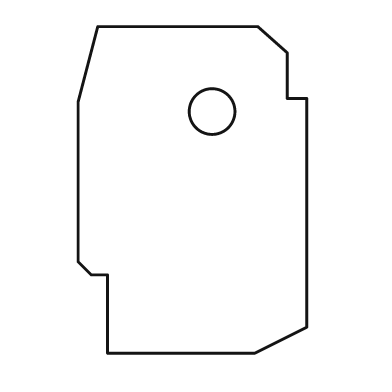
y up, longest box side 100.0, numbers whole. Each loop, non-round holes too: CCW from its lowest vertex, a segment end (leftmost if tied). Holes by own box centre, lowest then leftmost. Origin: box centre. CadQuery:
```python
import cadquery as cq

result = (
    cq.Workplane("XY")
    .moveTo(-26.0, -50.0)
    .lineTo(19.0, -50.0)
    .lineTo(35.0, -42.0)
    .lineTo(35.0, 28.0)
    .lineTo(29.0, 28.0)
    .lineTo(29.0, 42.0)
    .lineTo(20.0, 50.0)
    .lineTo(-29.0, 50.0)
    .lineTo(-35.0, 27.0)
    .lineTo(-35.0, -22.0)
    .lineTo(-31.0, -26.0)
    .lineTo(-26.0, -26.0)
    .close()
    .moveTo(6.0, 24.0)
    .circle(7.0)
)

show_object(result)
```